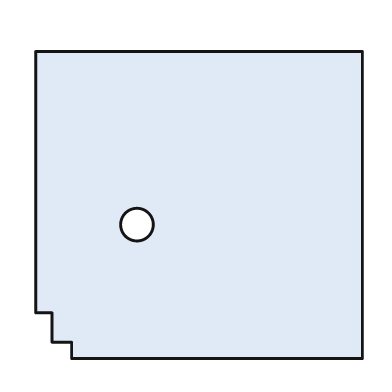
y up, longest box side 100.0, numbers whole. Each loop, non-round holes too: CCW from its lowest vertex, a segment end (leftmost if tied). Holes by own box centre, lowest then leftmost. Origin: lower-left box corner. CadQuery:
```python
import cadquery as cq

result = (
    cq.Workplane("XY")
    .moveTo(11.0, 0.0)
    .lineTo(100.0, 0.0)
    .lineTo(100.0, 94.0)
    .lineTo(0.0, 94.0)
    .lineTo(0.0, 14.0)
    .lineTo(5.0, 14.0)
    .lineTo(5.0, 5.0)
    .lineTo(11.0, 5.0)
    .close()
    .moveTo(31.0, 41.0)
    .circle(5.0)
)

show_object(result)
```